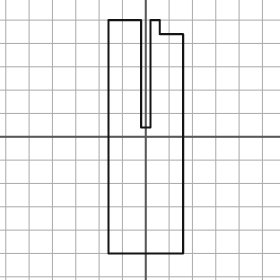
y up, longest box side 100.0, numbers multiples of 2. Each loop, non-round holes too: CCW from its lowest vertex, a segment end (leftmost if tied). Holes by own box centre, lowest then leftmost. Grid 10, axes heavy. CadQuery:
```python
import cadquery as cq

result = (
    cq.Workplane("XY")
    .moveTo(-16.0, -50.0)
    .lineTo(16.0, -50.0)
    .lineTo(16.0, 44.0)
    .lineTo(6.0, 44.0)
    .lineTo(6.0, 50.0)
    .lineTo(2.0, 50.0)
    .lineTo(2.0, 4.0)
    .lineTo(-2.0, 4.0)
    .lineTo(-2.0, 50.0)
    .lineTo(-16.0, 50.0)
    .close()
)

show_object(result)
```